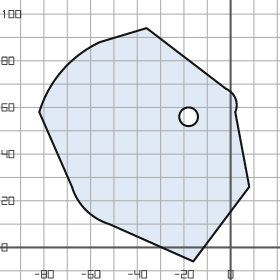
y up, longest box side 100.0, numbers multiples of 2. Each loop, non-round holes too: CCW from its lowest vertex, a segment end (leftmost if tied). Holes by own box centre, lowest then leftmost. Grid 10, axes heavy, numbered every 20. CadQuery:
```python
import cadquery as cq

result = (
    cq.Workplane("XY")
    .moveTo(-16.0, -6.0)
    .lineTo(8.0, 26.0)
    .lineTo(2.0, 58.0)
    .threePointArc((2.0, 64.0), (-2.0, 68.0))
    .lineTo(-36.0, 94.0)
    .lineTo(-56.0, 88.0)
    .threePointArc((-72.0, 76.0), (-82.0, 58.0))
    .lineTo(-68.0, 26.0)
    .threePointArc((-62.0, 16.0), (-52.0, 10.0))
    .close()
    .moveTo(-18.0, 56.0)
    .circle(4.0)
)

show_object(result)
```